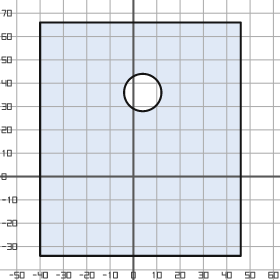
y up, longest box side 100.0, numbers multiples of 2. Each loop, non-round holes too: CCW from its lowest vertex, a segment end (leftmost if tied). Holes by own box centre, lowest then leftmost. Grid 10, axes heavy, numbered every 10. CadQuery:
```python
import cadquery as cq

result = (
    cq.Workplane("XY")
    .moveTo(-40.0, -34.0)
    .lineTo(46.0, -34.0)
    .lineTo(46.0, 66.0)
    .lineTo(-40.0, 66.0)
    .close()
    .moveTo(4.0, 36.0)
    .circle(8.0)
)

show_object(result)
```